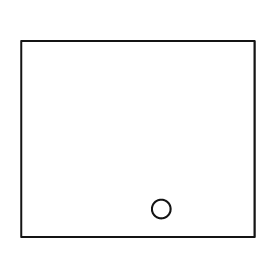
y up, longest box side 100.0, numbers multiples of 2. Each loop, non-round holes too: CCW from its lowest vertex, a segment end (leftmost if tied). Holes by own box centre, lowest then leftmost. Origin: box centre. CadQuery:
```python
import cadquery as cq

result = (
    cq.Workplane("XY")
    .moveTo(-50.0, -42.0)
    .lineTo(50.0, -42.0)
    .lineTo(50.0, 42.0)
    .lineTo(-50.0, 42.0)
    .close()
    .moveTo(10.0, -30.0)
    .circle(4.0)
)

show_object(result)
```